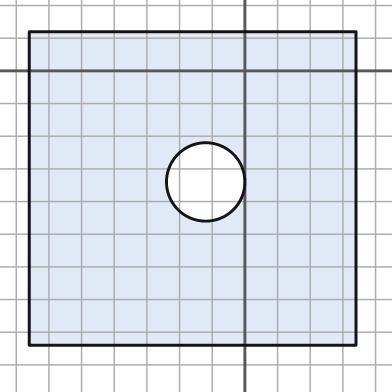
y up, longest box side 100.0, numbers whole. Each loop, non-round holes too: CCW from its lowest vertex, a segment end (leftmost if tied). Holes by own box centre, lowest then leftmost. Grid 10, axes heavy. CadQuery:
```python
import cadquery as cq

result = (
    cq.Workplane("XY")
    .moveTo(-66.0, -84.0)
    .lineTo(34.0, -84.0)
    .lineTo(34.0, 12.0)
    .lineTo(-66.0, 12.0)
    .close()
    .moveTo(-12.0, -34.0)
    .circle(12.0)
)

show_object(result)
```